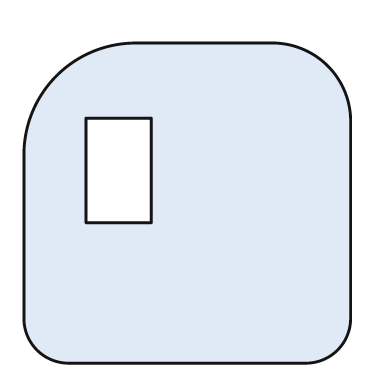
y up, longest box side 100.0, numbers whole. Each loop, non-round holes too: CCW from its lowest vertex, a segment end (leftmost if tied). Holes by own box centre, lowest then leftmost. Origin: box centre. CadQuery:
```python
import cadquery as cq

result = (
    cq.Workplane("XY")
    .moveTo(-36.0, -49.0)
    .lineTo(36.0, -49.0)
    .threePointArc((46.0, -45.0), (50.0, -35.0))
    .lineTo(50.0, 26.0)
    .threePointArc((43.0, 42.0), (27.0, 49.0))
    .lineTo(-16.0, 49.0)
    .threePointArc((-40.0, 39.0), (-50.0, 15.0))
    .lineTo(-50.0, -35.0)
    .threePointArc((-46.0, -45.0), (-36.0, -49.0))
    .close()
    .moveTo(-31.0, -6.0)
    .lineTo(-11.0, -6.0)
    .lineTo(-11.0, 26.0)
    .lineTo(-31.0, 26.0)
    .close()
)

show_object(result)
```